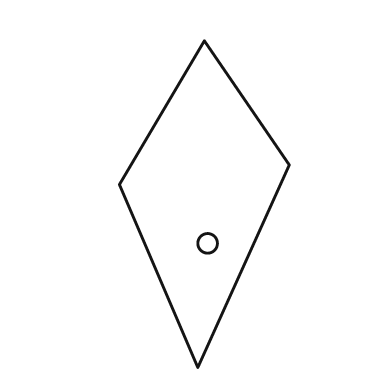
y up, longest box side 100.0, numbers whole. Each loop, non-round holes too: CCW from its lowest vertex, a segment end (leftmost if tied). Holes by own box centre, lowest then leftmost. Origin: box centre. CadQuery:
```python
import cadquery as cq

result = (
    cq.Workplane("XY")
    .moveTo(-2.0, -50.0)
    .lineTo(26.0, 12.0)
    .lineTo(0.0, 50.0)
    .lineTo(-26.0, 6.0)
    .close()
    .moveTo(1.0, -12.0)
    .circle(3.0)
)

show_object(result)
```